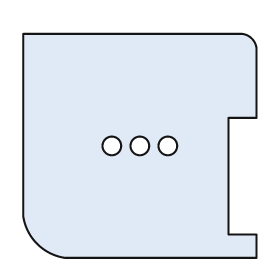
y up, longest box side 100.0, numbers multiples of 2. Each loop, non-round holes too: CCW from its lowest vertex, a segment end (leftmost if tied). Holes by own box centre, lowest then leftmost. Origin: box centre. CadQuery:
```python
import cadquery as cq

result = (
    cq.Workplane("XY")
    .moveTo(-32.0, -48.0)
    .lineTo(50.0, -48.0)
    .lineTo(50.0, -38.0)
    .lineTo(38.0, -38.0)
    .lineTo(38.0, 12.0)
    .lineTo(50.0, 12.0)
    .lineTo(50.0, 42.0)
    .threePointArc((48.0, 46.0), (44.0, 48.0))
    .lineTo(-50.0, 48.0)
    .lineTo(-50.0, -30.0)
    .threePointArc((-44.0, -42.0), (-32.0, -48.0))
    .close()
    .moveTo(-12.0, 0.0)
    .circle(4.0)
    .moveTo(0.0, 0.0)
    .circle(4.0)
    .moveTo(12.0, 0.0)
    .circle(4.0)
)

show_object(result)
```